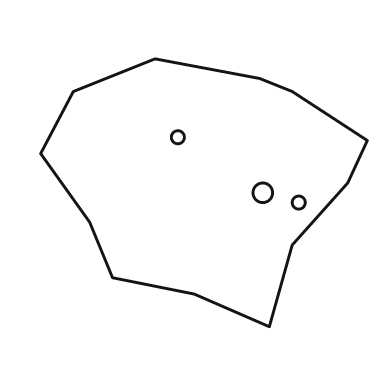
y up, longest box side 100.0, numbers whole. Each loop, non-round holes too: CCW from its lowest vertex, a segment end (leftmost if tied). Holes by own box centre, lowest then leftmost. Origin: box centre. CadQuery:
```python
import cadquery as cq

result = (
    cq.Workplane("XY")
    .moveTo(20.0, -41.0)
    .lineTo(27.0, -16.0)
    .lineTo(44.0, 3.0)
    .lineTo(50.0, 16.0)
    .lineTo(27.0, 31.0)
    .lineTo(17.0, 35.0)
    .lineTo(-15.0, 41.0)
    .lineTo(-40.0, 31.0)
    .lineTo(-50.0, 12.0)
    .lineTo(-35.0, -9.0)
    .lineTo(-28.0, -26.0)
    .lineTo(-3.0, -31.0)
    .close()
    .moveTo(29.0, -3.0)
    .circle(2.0)
    .moveTo(18.0, 0.0)
    .circle(3.0)
    .moveTo(-8.0, 17.0)
    .circle(2.0)
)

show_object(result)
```